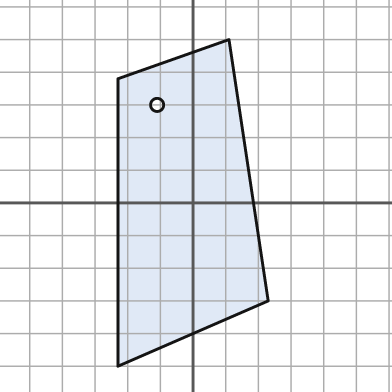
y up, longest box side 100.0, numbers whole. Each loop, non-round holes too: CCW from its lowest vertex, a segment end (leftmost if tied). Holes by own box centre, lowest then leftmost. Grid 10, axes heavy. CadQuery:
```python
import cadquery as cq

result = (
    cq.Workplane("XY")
    .moveTo(-23.0, -50.0)
    .lineTo(23.0, -30.0)
    .lineTo(11.0, 50.0)
    .lineTo(-23.0, 38.0)
    .close()
    .moveTo(-11.0, 30.0)
    .circle(2.0)
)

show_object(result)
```